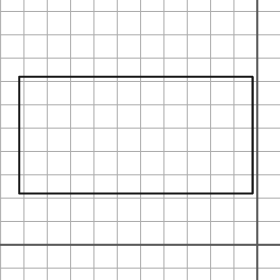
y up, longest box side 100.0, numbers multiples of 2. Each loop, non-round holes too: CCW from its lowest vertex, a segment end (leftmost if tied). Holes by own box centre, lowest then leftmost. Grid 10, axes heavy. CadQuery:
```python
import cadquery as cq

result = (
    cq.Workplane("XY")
    .moveTo(-102.0, 22.0)
    .lineTo(-2.0, 22.0)
    .lineTo(-2.0, 72.0)
    .lineTo(-102.0, 72.0)
    .close()
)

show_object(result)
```